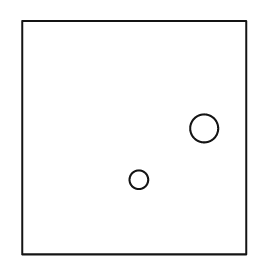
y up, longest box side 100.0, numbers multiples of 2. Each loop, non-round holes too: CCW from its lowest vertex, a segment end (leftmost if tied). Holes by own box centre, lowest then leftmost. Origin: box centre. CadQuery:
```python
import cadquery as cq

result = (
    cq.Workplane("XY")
    .moveTo(-48.0, -50.0)
    .lineTo(48.0, -50.0)
    .lineTo(48.0, 50.0)
    .lineTo(-48.0, 50.0)
    .close()
    .moveTo(2.0, -18.0)
    .circle(4.0)
    .moveTo(30.0, 4.0)
    .circle(6.0)
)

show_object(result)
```